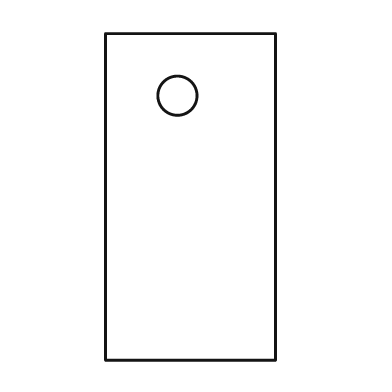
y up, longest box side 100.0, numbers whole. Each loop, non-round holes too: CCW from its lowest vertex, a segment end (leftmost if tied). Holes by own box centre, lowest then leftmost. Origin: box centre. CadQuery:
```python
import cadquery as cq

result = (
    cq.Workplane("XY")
    .moveTo(-26.0, -50.0)
    .lineTo(26.0, -50.0)
    .lineTo(26.0, 50.0)
    .lineTo(-26.0, 50.0)
    .close()
    .moveTo(-4.0, 31.0)
    .circle(6.0)
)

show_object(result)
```